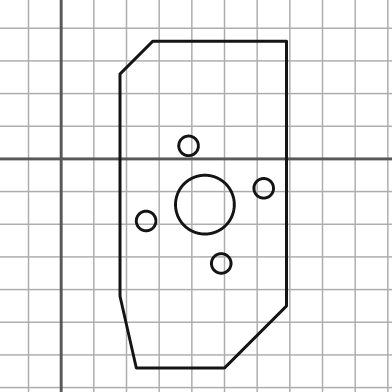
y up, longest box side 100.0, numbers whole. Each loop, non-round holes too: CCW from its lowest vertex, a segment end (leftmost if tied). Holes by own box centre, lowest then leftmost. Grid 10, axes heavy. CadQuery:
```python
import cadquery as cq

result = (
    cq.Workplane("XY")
    .moveTo(23.0, -64.0)
    .lineTo(50.0, -64.0)
    .lineTo(69.0, -45.0)
    .lineTo(69.0, 36.0)
    .lineTo(28.0, 36.0)
    .lineTo(18.0, 26.0)
    .lineTo(18.0, -42.0)
    .close()
    .moveTo(49.0, -32.0)
    .circle(3.0)
    .moveTo(26.0, -19.0)
    .circle(3.0)
    .moveTo(44.0, -14.0)
    .circle(9.0)
    .moveTo(62.0, -9.0)
    .circle(3.0)
    .moveTo(39.0, 4.0)
    .circle(3.0)
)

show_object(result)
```